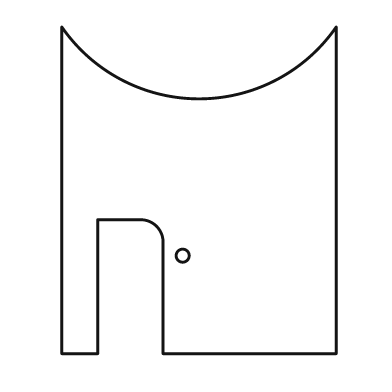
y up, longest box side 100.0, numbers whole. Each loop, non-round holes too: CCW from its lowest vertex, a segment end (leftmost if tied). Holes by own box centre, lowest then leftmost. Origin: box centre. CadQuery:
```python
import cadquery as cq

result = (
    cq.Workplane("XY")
    .moveTo(-42.0, -50.0)
    .lineTo(-31.0, -50.0)
    .lineTo(-31.0, -9.0)
    .lineTo(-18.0, -9.0)
    .threePointArc((-13.0, -11.0), (-11.0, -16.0))
    .lineTo(-11.0, -50.0)
    .lineTo(42.0, -50.0)
    .lineTo(42.0, 50.0)
    .threePointArc((0.0, 28.0), (-42.0, 50.0))
    .close()
    .moveTo(-5.0, -20.0)
    .circle(2.0)
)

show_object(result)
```